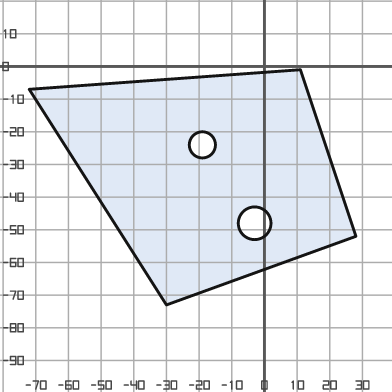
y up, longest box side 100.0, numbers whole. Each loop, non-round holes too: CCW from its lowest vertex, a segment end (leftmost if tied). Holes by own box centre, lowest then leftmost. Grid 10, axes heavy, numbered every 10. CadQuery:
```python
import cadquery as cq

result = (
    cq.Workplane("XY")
    .moveTo(-30.0, -73.0)
    .lineTo(28.0, -52.0)
    .lineTo(11.0, -1.0)
    .lineTo(-72.0, -7.0)
    .close()
    .moveTo(-3.0, -48.0)
    .circle(5.0)
    .moveTo(-19.0, -24.0)
    .circle(4.0)
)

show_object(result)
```